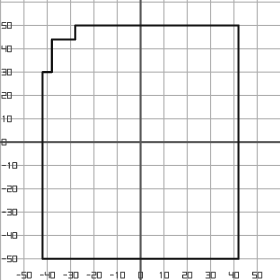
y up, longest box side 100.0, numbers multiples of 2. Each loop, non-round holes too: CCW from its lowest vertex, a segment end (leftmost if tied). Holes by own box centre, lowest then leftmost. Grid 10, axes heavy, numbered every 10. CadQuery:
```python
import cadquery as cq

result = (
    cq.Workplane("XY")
    .moveTo(-42.0, -50.0)
    .lineTo(42.0, -50.0)
    .lineTo(42.0, 50.0)
    .lineTo(-28.0, 50.0)
    .lineTo(-28.0, 44.0)
    .lineTo(-38.0, 44.0)
    .lineTo(-38.0, 30.0)
    .lineTo(-42.0, 30.0)
    .close()
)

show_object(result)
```